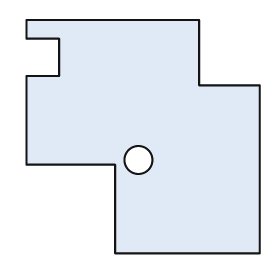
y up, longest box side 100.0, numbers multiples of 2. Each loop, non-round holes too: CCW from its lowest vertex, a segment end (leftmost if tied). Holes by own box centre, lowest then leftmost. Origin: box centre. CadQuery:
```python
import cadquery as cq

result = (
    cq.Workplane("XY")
    .moveTo(-12.0, -50.0)
    .lineTo(50.0, -50.0)
    .lineTo(50.0, 22.0)
    .lineTo(24.0, 22.0)
    .lineTo(24.0, 50.0)
    .lineTo(-50.0, 50.0)
    .lineTo(-50.0, 42.0)
    .lineTo(-36.0, 42.0)
    .lineTo(-36.0, 26.0)
    .lineTo(-50.0, 26.0)
    .lineTo(-50.0, -12.0)
    .lineTo(-12.0, -12.0)
    .close()
    .moveTo(-2.0, -10.0)
    .circle(6.0)
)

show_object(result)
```